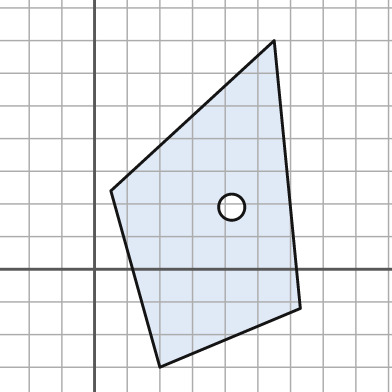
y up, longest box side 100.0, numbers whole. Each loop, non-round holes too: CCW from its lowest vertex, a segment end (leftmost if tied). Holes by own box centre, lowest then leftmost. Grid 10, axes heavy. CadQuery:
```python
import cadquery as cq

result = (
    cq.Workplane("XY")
    .moveTo(20.0, -30.0)
    .lineTo(63.0, -12.0)
    .lineTo(55.0, 70.0)
    .lineTo(5.0, 24.0)
    .close()
    .moveTo(42.0, 19.0)
    .circle(4.0)
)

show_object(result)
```